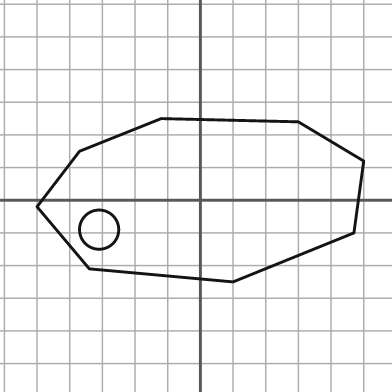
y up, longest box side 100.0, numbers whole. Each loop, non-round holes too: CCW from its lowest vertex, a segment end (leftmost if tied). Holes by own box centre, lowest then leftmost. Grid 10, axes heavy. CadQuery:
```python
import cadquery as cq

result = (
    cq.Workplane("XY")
    .moveTo(10.0, -25.0)
    .lineTo(47.0, -10.0)
    .lineTo(50.0, 12.0)
    .lineTo(30.0, 24.0)
    .lineTo(-12.0, 25.0)
    .lineTo(-37.0, 15.0)
    .lineTo(-50.0, -2.0)
    .lineTo(-34.0, -21.0)
    .close()
    .moveTo(-31.0, -9.0)
    .circle(6.0)
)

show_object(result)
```